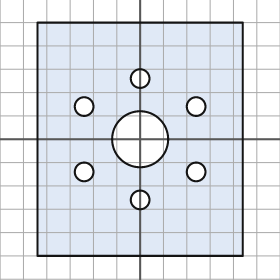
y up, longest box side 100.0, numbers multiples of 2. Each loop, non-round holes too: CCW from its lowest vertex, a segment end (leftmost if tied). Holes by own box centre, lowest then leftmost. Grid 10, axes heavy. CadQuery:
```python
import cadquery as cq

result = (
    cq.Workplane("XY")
    .moveTo(-44.0, -50.0)
    .lineTo(44.0, -50.0)
    .lineTo(44.0, 50.0)
    .lineTo(-44.0, 50.0)
    .close()
    .moveTo(0.0, -26.0)
    .circle(4.0)
    .moveTo(-24.0, -14.0)
    .circle(4.0)
    .moveTo(24.0, -14.0)
    .circle(4.0)
    .moveTo(0.0, 0.0)
    .circle(12.0)
    .moveTo(-24.0, 14.0)
    .circle(4.0)
    .moveTo(24.0, 14.0)
    .circle(4.0)
    .moveTo(0.0, 26.0)
    .circle(4.0)
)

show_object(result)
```